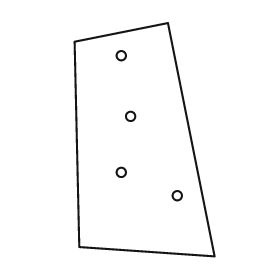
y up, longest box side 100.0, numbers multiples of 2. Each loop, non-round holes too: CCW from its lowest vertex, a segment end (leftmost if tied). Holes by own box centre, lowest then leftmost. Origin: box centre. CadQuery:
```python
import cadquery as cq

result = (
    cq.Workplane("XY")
    .moveTo(30.0, -50.0)
    .lineTo(10.0, 50.0)
    .lineTo(-30.0, 42.0)
    .lineTo(-28.0, -46.0)
    .close()
    .moveTo(14.0, -24.0)
    .circle(2.0)
    .moveTo(-10.0, -14.0)
    .circle(2.0)
    .moveTo(-6.0, 10.0)
    .circle(2.0)
    .moveTo(-10.0, 36.0)
    .circle(2.0)
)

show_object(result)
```